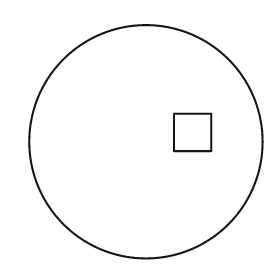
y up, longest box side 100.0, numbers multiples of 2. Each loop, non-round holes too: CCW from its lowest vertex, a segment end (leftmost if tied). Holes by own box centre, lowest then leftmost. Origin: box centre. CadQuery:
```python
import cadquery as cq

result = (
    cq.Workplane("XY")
    .moveTo(0.0, 0.0)
    .circle(50.0)
    .moveTo(12.0, -4.0)
    .lineTo(28.0, -4.0)
    .lineTo(28.0, 12.0)
    .lineTo(12.0, 12.0)
    .close()
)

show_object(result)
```